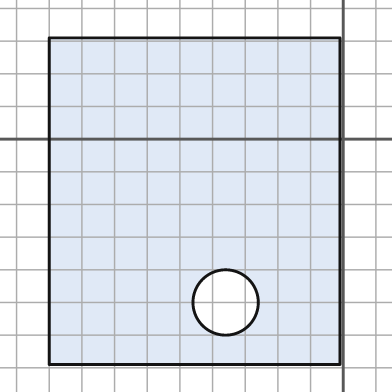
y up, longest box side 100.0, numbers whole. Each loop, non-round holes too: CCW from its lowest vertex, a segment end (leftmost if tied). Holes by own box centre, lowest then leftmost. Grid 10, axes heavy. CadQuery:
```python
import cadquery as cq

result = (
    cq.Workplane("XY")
    .moveTo(-90.0, -69.0)
    .lineTo(-1.0, -69.0)
    .lineTo(-1.0, 31.0)
    .lineTo(-90.0, 31.0)
    .close()
    .moveTo(-36.0, -50.0)
    .circle(10.0)
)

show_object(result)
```